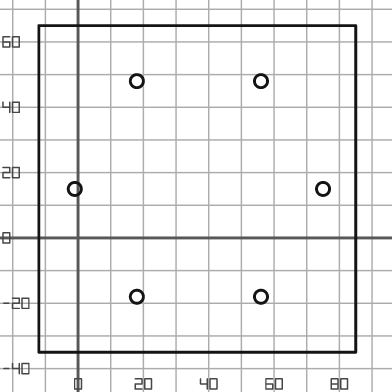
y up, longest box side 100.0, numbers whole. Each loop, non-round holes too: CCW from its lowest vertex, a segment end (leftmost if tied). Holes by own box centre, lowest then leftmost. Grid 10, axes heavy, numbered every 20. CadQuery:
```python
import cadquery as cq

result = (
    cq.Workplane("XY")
    .moveTo(-12.0, -35.0)
    .lineTo(85.0, -35.0)
    .lineTo(85.0, 65.0)
    .lineTo(-12.0, 65.0)
    .close()
    .moveTo(18.0, -18.0)
    .circle(2.0)
    .moveTo(56.0, -18.0)
    .circle(2.0)
    .moveTo(-1.0, 15.0)
    .circle(2.0)
    .moveTo(75.0, 15.0)
    .circle(2.0)
    .moveTo(18.0, 48.0)
    .circle(2.0)
    .moveTo(56.0, 48.0)
    .circle(2.0)
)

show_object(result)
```